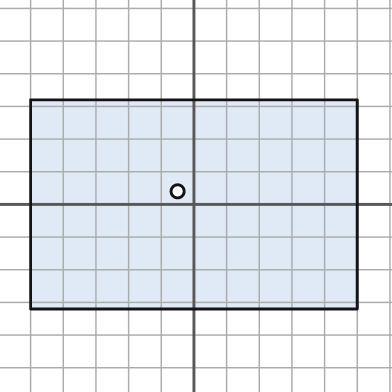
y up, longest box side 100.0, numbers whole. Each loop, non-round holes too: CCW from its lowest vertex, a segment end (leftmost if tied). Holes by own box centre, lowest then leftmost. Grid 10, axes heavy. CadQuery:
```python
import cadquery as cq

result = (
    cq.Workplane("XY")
    .moveTo(-50.0, -32.0)
    .lineTo(50.0, -32.0)
    .lineTo(50.0, 32.0)
    .lineTo(-50.0, 32.0)
    .close()
    .moveTo(-5.0, 4.0)
    .circle(2.0)
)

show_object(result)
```